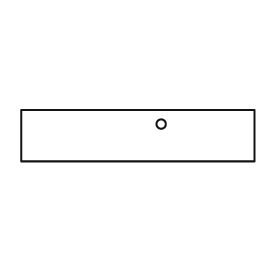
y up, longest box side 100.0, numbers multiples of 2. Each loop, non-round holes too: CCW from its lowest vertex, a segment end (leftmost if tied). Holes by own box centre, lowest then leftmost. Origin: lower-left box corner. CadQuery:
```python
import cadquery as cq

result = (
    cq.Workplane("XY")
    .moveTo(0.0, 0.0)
    .lineTo(100.0, 0.0)
    .lineTo(100.0, 22.0)
    .lineTo(0.0, 22.0)
    .close()
    .moveTo(60.0, 16.0)
    .circle(2.0)
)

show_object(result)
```